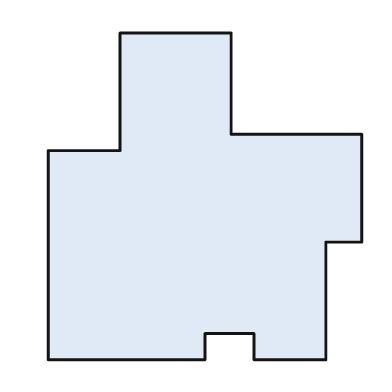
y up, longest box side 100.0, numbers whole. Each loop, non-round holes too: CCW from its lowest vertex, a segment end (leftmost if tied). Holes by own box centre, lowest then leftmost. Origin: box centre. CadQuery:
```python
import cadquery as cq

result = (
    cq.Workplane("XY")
    .moveTo(-48.0, -50.0)
    .lineTo(0.0, -50.0)
    .lineTo(0.0, -42.0)
    .lineTo(15.0, -42.0)
    .lineTo(15.0, -50.0)
    .lineTo(37.0, -50.0)
    .lineTo(37.0, -14.0)
    .lineTo(48.0, -14.0)
    .lineTo(48.0, 19.0)
    .lineTo(8.0, 19.0)
    .lineTo(8.0, 50.0)
    .lineTo(-26.0, 50.0)
    .lineTo(-26.0, 14.0)
    .lineTo(-48.0, 14.0)
    .close()
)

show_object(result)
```